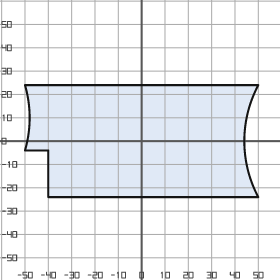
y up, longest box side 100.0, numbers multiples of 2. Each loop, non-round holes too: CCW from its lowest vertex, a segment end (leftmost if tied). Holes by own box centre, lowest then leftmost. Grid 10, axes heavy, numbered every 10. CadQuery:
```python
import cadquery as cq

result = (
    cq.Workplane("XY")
    .moveTo(-40.0, -24.0)
    .lineTo(50.0, -24.0)
    .threePointArc((44.0, 0.0), (50.0, 24.0))
    .lineTo(-50.0, 24.0)
    .threePointArc((-48.0, 10.0), (-50.0, -4.0))
    .lineTo(-40.0, -4.0)
    .close()
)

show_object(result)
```